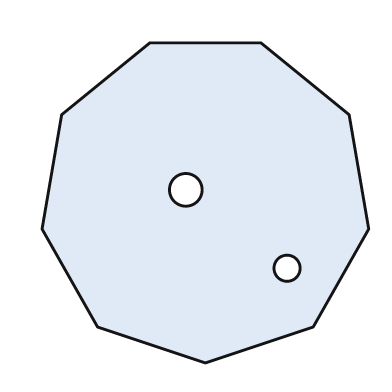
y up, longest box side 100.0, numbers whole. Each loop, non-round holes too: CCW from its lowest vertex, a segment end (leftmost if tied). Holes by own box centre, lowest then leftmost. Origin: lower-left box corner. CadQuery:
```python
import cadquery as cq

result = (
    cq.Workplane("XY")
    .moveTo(50.0, 0.0)
    .lineTo(83.0, 11.0)
    .lineTo(100.0, 41.0)
    .lineTo(94.0, 76.0)
    .lineTo(67.0, 98.0)
    .lineTo(33.0, 98.0)
    .lineTo(6.0, 76.0)
    .lineTo(0.0, 41.0)
    .lineTo(17.0, 11.0)
    .close()
    .moveTo(75.0, 29.0)
    .circle(4.0)
    .moveTo(44.0, 53.0)
    .circle(5.0)
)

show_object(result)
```